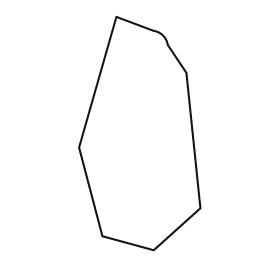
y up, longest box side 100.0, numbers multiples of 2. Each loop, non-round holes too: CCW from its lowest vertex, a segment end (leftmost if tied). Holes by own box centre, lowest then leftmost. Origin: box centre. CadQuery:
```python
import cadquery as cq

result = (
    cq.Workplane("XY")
    .moveTo(6.0, -50.0)
    .lineTo(26.0, -32.0)
    .lineTo(20.0, 26.0)
    .lineTo(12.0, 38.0)
    .threePointArc((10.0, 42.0), (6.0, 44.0))
    .lineTo(-10.0, 50.0)
    .lineTo(-26.0, -6.0)
    .lineTo(-16.0, -44.0)
    .close()
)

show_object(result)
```